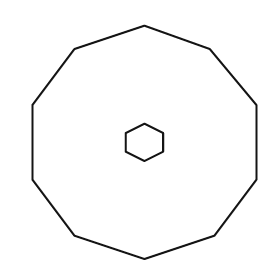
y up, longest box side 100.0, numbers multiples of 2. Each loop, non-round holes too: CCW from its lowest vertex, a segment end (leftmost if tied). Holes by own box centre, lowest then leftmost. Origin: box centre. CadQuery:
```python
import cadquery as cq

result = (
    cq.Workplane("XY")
    .moveTo(0.0, -50.0)
    .lineTo(30.0, -40.0)
    .lineTo(48.0, -16.0)
    .lineTo(48.0, 16.0)
    .lineTo(28.0, 40.0)
    .lineTo(0.0, 50.0)
    .lineTo(-30.0, 40.0)
    .lineTo(-48.0, 16.0)
    .lineTo(-48.0, -16.0)
    .lineTo(-30.0, -40.0)
    .close()
    .moveTo(0.0, -8.0)
    .lineTo(8.0, -4.0)
    .lineTo(8.0, 4.0)
    .lineTo(0.0, 8.0)
    .lineTo(-8.0, 4.0)
    .lineTo(-8.0, -4.0)
    .close()
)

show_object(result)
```